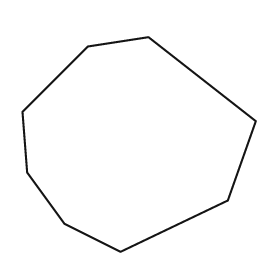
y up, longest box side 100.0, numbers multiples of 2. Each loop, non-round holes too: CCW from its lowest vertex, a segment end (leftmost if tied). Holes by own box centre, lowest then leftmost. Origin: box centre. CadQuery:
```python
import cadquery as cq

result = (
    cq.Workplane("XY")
    .moveTo(-8.0, -46.0)
    .lineTo(38.0, -24.0)
    .lineTo(50.0, 10.0)
    .lineTo(4.0, 46.0)
    .lineTo(-22.0, 42.0)
    .lineTo(-50.0, 14.0)
    .lineTo(-48.0, -12.0)
    .lineTo(-32.0, -34.0)
    .close()
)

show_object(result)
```